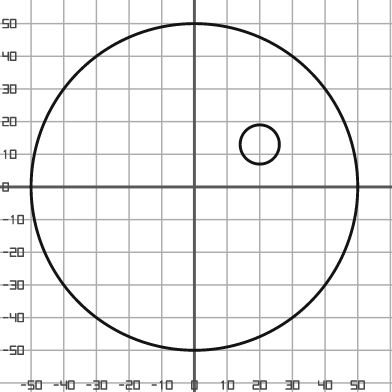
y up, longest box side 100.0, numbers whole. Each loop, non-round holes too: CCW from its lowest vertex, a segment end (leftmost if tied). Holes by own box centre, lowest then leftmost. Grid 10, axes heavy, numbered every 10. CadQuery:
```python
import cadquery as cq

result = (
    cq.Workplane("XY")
    .moveTo(0.0, 0.0)
    .circle(50.0)
    .moveTo(20.0, 13.0)
    .circle(6.0)
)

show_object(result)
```